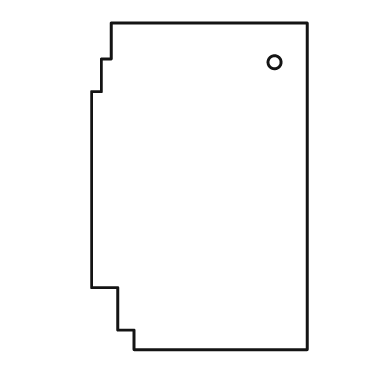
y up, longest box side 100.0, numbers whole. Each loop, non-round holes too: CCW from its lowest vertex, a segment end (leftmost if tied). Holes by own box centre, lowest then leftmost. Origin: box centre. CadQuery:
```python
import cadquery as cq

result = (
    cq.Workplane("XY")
    .moveTo(-20.0, -50.0)
    .lineTo(33.0, -50.0)
    .lineTo(33.0, 50.0)
    .lineTo(-27.0, 50.0)
    .lineTo(-27.0, 39.0)
    .lineTo(-30.0, 39.0)
    .lineTo(-30.0, 29.0)
    .lineTo(-33.0, 29.0)
    .lineTo(-33.0, -31.0)
    .lineTo(-25.0, -31.0)
    .lineTo(-25.0, -44.0)
    .lineTo(-20.0, -44.0)
    .close()
    .moveTo(23.0, 38.0)
    .circle(2.0)
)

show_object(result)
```